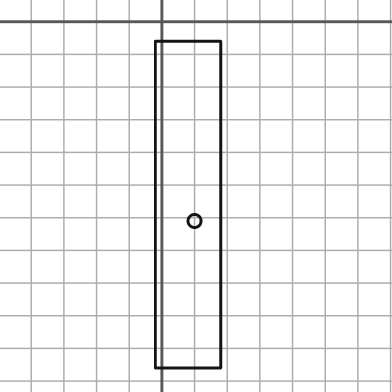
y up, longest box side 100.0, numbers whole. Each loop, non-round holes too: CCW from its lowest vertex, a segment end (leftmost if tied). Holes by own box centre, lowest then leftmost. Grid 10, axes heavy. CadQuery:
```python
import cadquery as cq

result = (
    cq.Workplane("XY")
    .moveTo(-2.0, -106.0)
    .lineTo(18.0, -106.0)
    .lineTo(18.0, -6.0)
    .lineTo(-2.0, -6.0)
    .close()
    .moveTo(10.0, -61.0)
    .circle(2.0)
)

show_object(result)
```